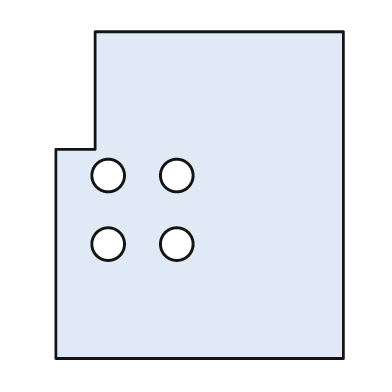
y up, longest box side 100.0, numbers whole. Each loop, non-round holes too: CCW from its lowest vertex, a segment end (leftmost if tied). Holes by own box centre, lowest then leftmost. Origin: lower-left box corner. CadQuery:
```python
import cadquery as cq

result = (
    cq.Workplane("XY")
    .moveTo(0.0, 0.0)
    .lineTo(88.0, 0.0)
    .lineTo(88.0, 100.0)
    .lineTo(12.0, 100.0)
    .lineTo(12.0, 64.0)
    .lineTo(0.0, 64.0)
    .close()
    .moveTo(16.0, 35.0)
    .circle(5.0)
    .moveTo(37.0, 35.0)
    .circle(5.0)
    .moveTo(16.0, 56.0)
    .circle(5.0)
    .moveTo(37.0, 56.0)
    .circle(5.0)
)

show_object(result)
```